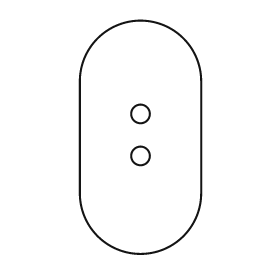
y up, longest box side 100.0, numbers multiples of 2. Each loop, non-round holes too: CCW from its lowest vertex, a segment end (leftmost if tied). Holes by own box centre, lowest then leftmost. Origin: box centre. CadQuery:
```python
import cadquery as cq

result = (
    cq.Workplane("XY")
    .moveTo(-26.0, -24.0)
    .threePointArc((0.0, -50.0), (26.0, -24.0))
    .lineTo(26.0, 24.0)
    .threePointArc((0.0, 50.0), (-26.0, 24.0))
    .close()
    .moveTo(0.0, -8.0)
    .circle(4.0)
    .moveTo(0.0, 10.0)
    .circle(4.0)
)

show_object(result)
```